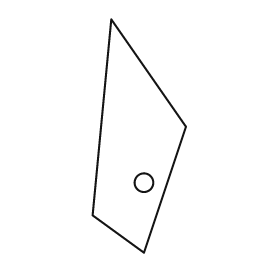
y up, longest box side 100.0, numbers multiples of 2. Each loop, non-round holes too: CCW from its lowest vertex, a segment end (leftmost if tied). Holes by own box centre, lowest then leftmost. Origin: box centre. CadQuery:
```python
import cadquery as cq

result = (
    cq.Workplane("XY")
    .moveTo(2.0, -50.0)
    .lineTo(20.0, 4.0)
    .lineTo(-12.0, 50.0)
    .lineTo(-20.0, -34.0)
    .close()
    .moveTo(2.0, -20.0)
    .circle(4.0)
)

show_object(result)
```